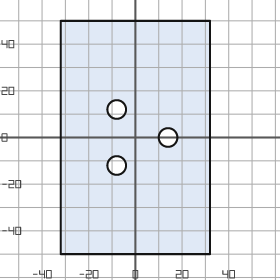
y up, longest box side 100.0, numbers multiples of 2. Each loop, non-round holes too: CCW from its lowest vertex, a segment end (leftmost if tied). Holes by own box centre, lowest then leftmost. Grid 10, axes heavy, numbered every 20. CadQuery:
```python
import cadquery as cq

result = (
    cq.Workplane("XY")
    .moveTo(-32.0, -50.0)
    .lineTo(32.0, -50.0)
    .lineTo(32.0, 50.0)
    .lineTo(-32.0, 50.0)
    .close()
    .moveTo(-8.0, -12.0)
    .circle(4.0)
    .moveTo(14.0, 0.0)
    .circle(4.0)
    .moveTo(-8.0, 12.0)
    .circle(4.0)
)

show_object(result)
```